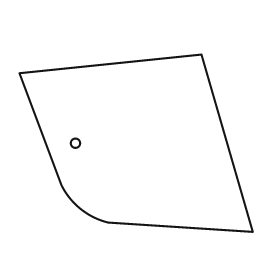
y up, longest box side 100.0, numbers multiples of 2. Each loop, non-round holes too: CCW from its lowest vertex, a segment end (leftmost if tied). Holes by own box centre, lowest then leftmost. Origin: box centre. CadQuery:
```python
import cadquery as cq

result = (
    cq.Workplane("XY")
    .moveTo(50.0, -38.0)
    .lineTo(28.0, 38.0)
    .lineTo(-50.0, 30.0)
    .lineTo(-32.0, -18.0)
    .threePointArc((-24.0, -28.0), (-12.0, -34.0))
    .close()
    .moveTo(-26.0, 0.0)
    .circle(2.0)
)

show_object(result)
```